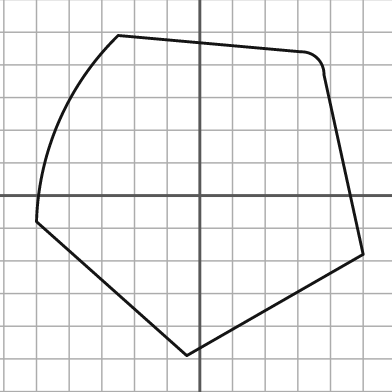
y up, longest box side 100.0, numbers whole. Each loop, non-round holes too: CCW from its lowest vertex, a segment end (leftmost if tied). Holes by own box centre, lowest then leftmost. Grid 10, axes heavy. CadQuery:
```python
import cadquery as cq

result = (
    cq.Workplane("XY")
    .moveTo(-4.0, -49.0)
    .lineTo(50.0, -18.0)
    .lineTo(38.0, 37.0)
    .threePointArc((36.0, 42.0), (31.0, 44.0))
    .lineTo(-25.0, 49.0)
    .threePointArc((-43.0, 23.0), (-50.0, -8.0))
    .close()
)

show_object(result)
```